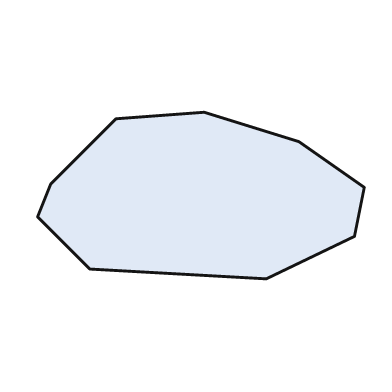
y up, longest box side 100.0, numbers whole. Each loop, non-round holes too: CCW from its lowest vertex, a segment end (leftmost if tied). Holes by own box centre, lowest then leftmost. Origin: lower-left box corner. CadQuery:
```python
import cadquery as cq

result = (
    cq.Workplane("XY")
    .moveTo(70.0, 0.0)
    .lineTo(97.0, 13.0)
    .lineTo(100.0, 28.0)
    .lineTo(80.0, 42.0)
    .lineTo(51.0, 51.0)
    .lineTo(24.0, 49.0)
    .lineTo(4.0, 29.0)
    .lineTo(0.0, 19.0)
    .lineTo(16.0, 3.0)
    .close()
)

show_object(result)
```